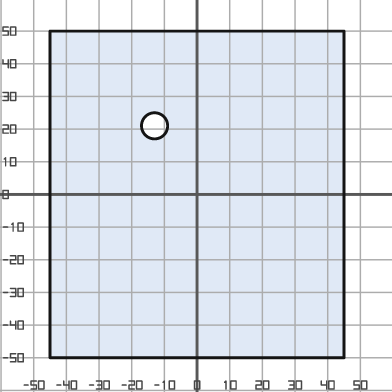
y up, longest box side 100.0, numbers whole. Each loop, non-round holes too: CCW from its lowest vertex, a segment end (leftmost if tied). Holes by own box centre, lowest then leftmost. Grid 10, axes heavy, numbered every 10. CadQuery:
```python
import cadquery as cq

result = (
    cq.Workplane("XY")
    .moveTo(-45.0, -50.0)
    .lineTo(45.0, -50.0)
    .lineTo(45.0, 50.0)
    .lineTo(-45.0, 50.0)
    .close()
    .moveTo(-13.0, 21.0)
    .circle(4.0)
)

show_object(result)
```